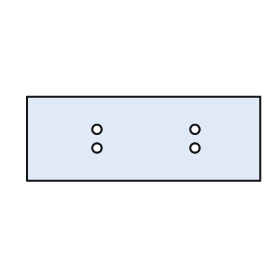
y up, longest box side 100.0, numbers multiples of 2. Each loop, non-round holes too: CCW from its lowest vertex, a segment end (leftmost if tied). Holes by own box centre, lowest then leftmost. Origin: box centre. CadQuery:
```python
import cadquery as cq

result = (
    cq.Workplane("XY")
    .moveTo(-50.0, -18.0)
    .lineTo(50.0, -18.0)
    .lineTo(50.0, 18.0)
    .lineTo(-50.0, 18.0)
    .close()
    .moveTo(-20.0, -4.0)
    .circle(2.0)
    .moveTo(22.0, -4.0)
    .circle(2.0)
    .moveTo(-20.0, 4.0)
    .circle(2.0)
    .moveTo(22.0, 4.0)
    .circle(2.0)
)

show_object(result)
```